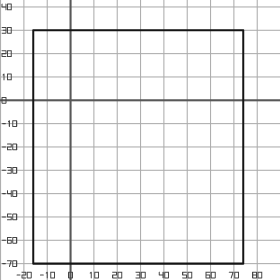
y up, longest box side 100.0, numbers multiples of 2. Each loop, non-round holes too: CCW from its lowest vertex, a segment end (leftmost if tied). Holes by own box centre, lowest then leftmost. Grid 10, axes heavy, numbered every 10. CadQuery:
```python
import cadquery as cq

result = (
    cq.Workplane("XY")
    .moveTo(-16.0, -70.0)
    .lineTo(74.0, -70.0)
    .lineTo(74.0, 30.0)
    .lineTo(-16.0, 30.0)
    .close()
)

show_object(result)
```